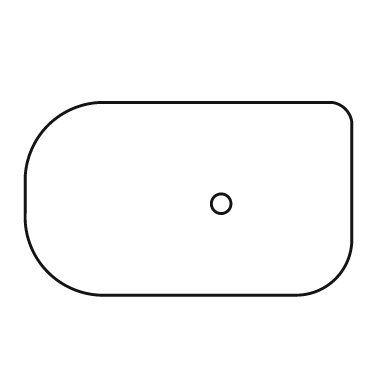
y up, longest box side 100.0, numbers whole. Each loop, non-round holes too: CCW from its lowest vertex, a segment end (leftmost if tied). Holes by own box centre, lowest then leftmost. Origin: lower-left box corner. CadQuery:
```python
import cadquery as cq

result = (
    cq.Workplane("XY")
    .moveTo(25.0, 0.0)
    .lineTo(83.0, 0.0)
    .threePointArc((95.0, 5.0), (100.0, 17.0))
    .lineTo(100.0, 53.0)
    .threePointArc((98.0, 57.0), (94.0, 59.0))
    .lineTo(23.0, 59.0)
    .threePointArc((7.0, 52.0), (0.0, 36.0))
    .lineTo(0.0, 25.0)
    .threePointArc((7.0, 7.0), (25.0, 0.0))
    .close()
    .moveTo(60.0, 28.0)
    .circle(3.0)
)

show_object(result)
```